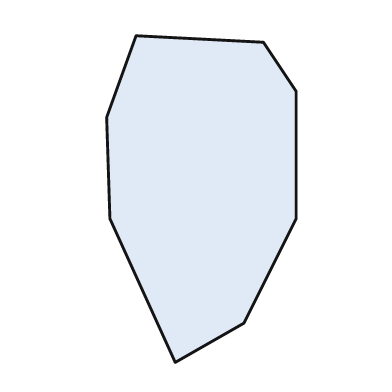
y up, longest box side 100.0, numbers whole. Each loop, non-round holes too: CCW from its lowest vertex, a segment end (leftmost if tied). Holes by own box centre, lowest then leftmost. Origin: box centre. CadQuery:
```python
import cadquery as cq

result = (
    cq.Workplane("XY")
    .moveTo(-8.0, -50.0)
    .lineTo(13.0, -38.0)
    .lineTo(29.0, -6.0)
    .lineTo(29.0, 33.0)
    .lineTo(19.0, 48.0)
    .lineTo(-20.0, 50.0)
    .lineTo(-29.0, 25.0)
    .lineTo(-28.0, -6.0)
    .close()
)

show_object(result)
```